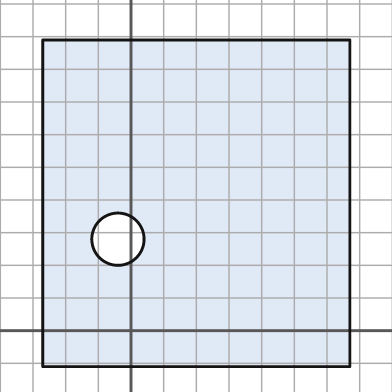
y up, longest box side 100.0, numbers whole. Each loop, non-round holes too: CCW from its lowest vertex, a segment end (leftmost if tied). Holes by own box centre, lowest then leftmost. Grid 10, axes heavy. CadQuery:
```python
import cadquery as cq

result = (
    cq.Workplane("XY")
    .moveTo(-27.0, -11.0)
    .lineTo(67.0, -11.0)
    .lineTo(67.0, 89.0)
    .lineTo(-27.0, 89.0)
    .close()
    .moveTo(-4.0, 28.0)
    .circle(8.0)
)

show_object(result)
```